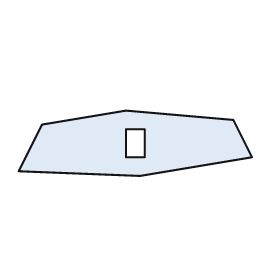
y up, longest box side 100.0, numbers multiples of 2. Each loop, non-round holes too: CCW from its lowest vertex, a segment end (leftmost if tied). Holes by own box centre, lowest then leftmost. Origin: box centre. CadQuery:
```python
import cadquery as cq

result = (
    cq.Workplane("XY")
    .moveTo(2.0, -14.0)
    .lineTo(50.0, -6.0)
    .lineTo(42.0, 10.0)
    .lineTo(-4.0, 14.0)
    .lineTo(-40.0, 8.0)
    .lineTo(-50.0, -12.0)
    .close()
    .moveTo(-4.0, -6.0)
    .lineTo(4.0, -6.0)
    .lineTo(4.0, 6.0)
    .lineTo(-4.0, 6.0)
    .close()
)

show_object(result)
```